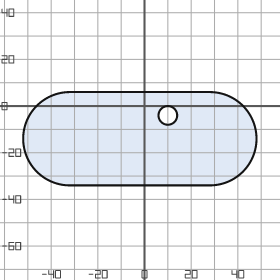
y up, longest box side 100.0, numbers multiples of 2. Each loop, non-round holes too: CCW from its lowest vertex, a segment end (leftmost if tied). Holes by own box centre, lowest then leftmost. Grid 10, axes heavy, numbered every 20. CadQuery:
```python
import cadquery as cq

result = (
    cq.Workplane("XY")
    .moveTo(-32.0, -34.0)
    .lineTo(28.0, -34.0)
    .threePointArc((48.0, -14.0), (28.0, 6.0))
    .lineTo(-32.0, 6.0)
    .threePointArc((-52.0, -14.0), (-32.0, -34.0))
    .close()
    .moveTo(10.0, -4.0)
    .circle(4.0)
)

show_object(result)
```